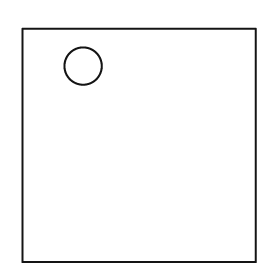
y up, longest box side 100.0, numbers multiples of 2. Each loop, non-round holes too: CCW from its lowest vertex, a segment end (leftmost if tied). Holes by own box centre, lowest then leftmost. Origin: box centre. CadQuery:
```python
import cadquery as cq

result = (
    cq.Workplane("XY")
    .moveTo(-50.0, -50.0)
    .lineTo(50.0, -50.0)
    .lineTo(50.0, 50.0)
    .lineTo(-50.0, 50.0)
    .close()
    .moveTo(-24.0, 34.0)
    .circle(8.0)
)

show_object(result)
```